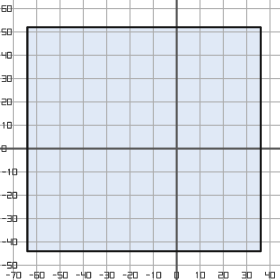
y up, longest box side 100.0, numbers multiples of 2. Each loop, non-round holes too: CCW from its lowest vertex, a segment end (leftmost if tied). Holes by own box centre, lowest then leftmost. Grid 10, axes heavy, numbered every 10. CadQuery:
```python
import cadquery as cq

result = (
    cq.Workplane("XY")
    .moveTo(-64.0, -44.0)
    .lineTo(36.0, -44.0)
    .lineTo(36.0, 52.0)
    .lineTo(-64.0, 52.0)
    .close()
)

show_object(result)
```